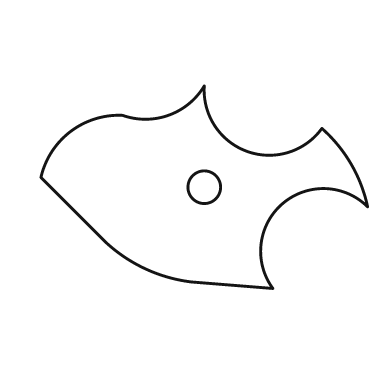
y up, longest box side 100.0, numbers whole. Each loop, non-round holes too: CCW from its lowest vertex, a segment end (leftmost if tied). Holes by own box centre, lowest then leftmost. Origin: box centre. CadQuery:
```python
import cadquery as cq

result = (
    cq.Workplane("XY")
    .moveTo(21.0, -31.0)
    .threePointArc((24.0, -5.0), (50.0, -6.0))
    .threePointArc((45.0, 7.0), (36.0, 18.0))
    .threePointArc((13.0, 11.0), (0.0, 31.0))
    .threePointArc((-11.0, 22.0), (-25.0, 22.0))
    .threePointArc((-41.0, 17.0), (-50.0, 3.0))
    .lineTo(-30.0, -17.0)
    .threePointArc((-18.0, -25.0), (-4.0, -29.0))
    .close()
    .moveTo(0.0, 0.0)
    .circle(5.0)
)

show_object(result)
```